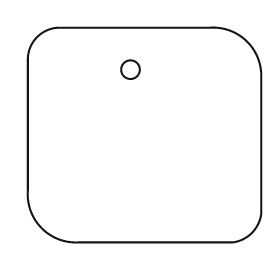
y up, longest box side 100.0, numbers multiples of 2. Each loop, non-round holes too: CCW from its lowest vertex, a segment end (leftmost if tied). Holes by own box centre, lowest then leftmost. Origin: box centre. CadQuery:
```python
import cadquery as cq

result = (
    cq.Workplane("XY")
    .moveTo(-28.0, -46.0)
    .lineTo(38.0, -46.0)
    .threePointArc((46.0, -42.0), (50.0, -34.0))
    .lineTo(50.0, 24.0)
    .threePointArc((44.0, 40.0), (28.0, 46.0))
    .lineTo(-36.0, 46.0)
    .threePointArc((-46.0, 42.0), (-50.0, 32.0))
    .lineTo(-50.0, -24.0)
    .threePointArc((-44.0, -40.0), (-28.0, -46.0))
    .close()
    .moveTo(-6.0, 28.0)
    .circle(4.0)
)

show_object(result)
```